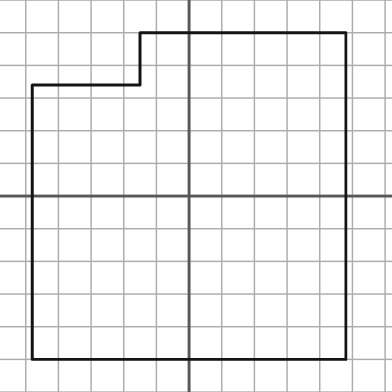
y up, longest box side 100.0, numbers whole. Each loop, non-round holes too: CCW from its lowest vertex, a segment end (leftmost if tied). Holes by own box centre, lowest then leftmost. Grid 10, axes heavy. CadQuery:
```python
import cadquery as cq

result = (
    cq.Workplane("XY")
    .moveTo(-48.0, -50.0)
    .lineTo(48.0, -50.0)
    .lineTo(48.0, 50.0)
    .lineTo(-15.0, 50.0)
    .lineTo(-15.0, 34.0)
    .lineTo(-48.0, 34.0)
    .close()
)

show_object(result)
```